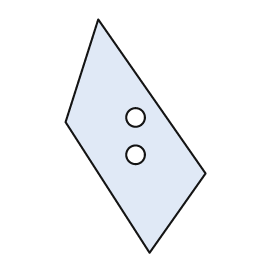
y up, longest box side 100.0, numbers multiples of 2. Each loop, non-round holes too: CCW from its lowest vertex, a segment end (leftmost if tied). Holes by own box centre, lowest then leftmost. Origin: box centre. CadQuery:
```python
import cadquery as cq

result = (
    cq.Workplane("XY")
    .moveTo(6.0, -50.0)
    .lineTo(30.0, -16.0)
    .lineTo(-16.0, 50.0)
    .lineTo(-30.0, 6.0)
    .close()
    .moveTo(0.0, -8.0)
    .circle(4.0)
    .moveTo(0.0, 8.0)
    .circle(4.0)
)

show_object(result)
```